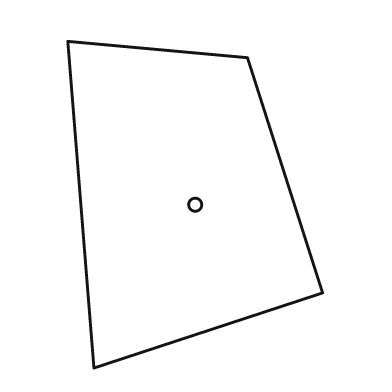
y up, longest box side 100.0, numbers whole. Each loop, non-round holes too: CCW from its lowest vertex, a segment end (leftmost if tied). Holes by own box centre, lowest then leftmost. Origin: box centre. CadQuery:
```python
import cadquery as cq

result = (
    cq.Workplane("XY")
    .moveTo(-31.0, -50.0)
    .lineTo(39.0, -27.0)
    .lineTo(16.0, 45.0)
    .lineTo(-39.0, 50.0)
    .close()
    .moveTo(0.0, 0.0)
    .circle(2.0)
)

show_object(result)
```